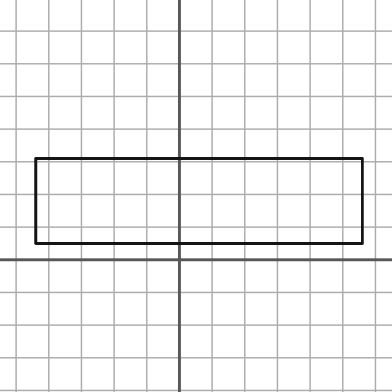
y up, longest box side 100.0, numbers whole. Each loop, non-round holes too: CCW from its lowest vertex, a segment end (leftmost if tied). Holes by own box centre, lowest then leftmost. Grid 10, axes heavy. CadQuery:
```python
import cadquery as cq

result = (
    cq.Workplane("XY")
    .moveTo(-44.0, 5.0)
    .lineTo(56.0, 5.0)
    .lineTo(56.0, 31.0)
    .lineTo(-44.0, 31.0)
    .close()
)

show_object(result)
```